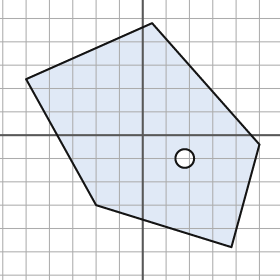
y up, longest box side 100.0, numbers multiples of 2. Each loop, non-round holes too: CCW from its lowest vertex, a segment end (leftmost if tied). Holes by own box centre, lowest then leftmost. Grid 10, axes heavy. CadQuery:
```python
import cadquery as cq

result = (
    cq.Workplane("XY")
    .moveTo(38.0, -48.0)
    .lineTo(50.0, -4.0)
    .lineTo(4.0, 48.0)
    .lineTo(-50.0, 24.0)
    .lineTo(-20.0, -30.0)
    .close()
    .moveTo(18.0, -10.0)
    .circle(4.0)
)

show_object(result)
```